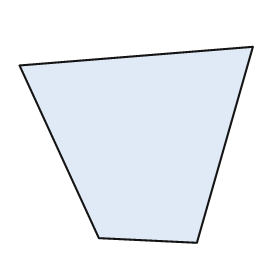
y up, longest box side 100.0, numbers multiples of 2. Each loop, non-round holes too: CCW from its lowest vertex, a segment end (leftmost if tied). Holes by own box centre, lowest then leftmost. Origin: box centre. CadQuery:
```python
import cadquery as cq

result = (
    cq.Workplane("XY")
    .moveTo(26.0, -42.0)
    .lineTo(50.0, 42.0)
    .lineTo(-50.0, 34.0)
    .lineTo(-16.0, -40.0)
    .close()
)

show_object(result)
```